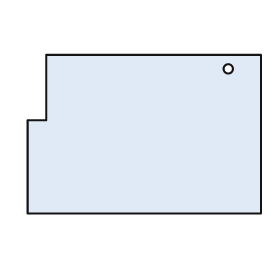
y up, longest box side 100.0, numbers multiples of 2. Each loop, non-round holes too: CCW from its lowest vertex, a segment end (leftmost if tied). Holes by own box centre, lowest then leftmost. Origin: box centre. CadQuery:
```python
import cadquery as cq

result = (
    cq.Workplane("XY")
    .moveTo(-50.0, -34.0)
    .lineTo(50.0, -34.0)
    .lineTo(50.0, 34.0)
    .lineTo(-42.0, 34.0)
    .lineTo(-42.0, 6.0)
    .lineTo(-50.0, 6.0)
    .close()
    .moveTo(36.0, 28.0)
    .circle(2.0)
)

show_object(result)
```